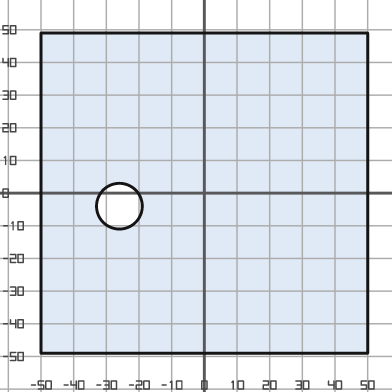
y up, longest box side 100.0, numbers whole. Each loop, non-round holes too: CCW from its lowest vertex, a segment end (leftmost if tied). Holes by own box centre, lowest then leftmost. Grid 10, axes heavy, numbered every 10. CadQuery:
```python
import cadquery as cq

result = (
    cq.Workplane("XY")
    .moveTo(-50.0, -49.0)
    .lineTo(50.0, -49.0)
    .lineTo(50.0, 49.0)
    .lineTo(-50.0, 49.0)
    .close()
    .moveTo(-26.0, -4.0)
    .circle(7.0)
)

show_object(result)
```